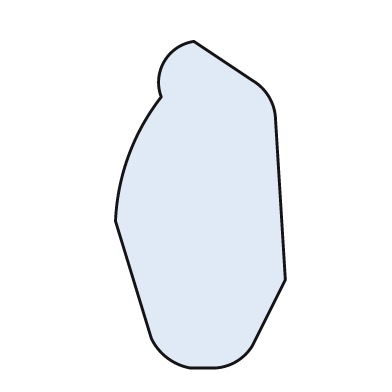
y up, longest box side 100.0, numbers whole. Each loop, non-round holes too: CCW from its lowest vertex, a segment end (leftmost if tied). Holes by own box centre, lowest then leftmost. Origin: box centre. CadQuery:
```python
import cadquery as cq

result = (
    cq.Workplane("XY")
    .moveTo(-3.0, -50.0)
    .lineTo(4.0, -50.0)
    .threePointArc((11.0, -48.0), (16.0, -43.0))
    .lineTo(26.0, -23.0)
    .lineTo(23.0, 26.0)
    .threePointArc((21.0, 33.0), (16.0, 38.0))
    .lineTo(-2.0, 50.0)
    .threePointArc((-11.0, 44.0), (-12.0, 33.0))
    .threePointArc((-22.0, 15.0), (-26.0, -5.0))
    .lineTo(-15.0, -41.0)
    .threePointArc((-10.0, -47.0), (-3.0, -50.0))
    .close()
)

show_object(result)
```